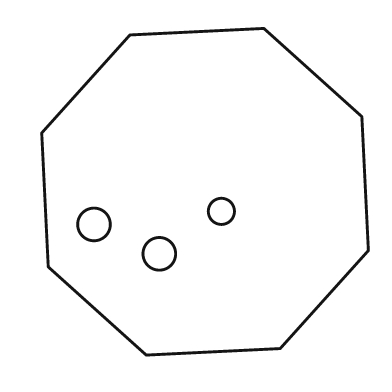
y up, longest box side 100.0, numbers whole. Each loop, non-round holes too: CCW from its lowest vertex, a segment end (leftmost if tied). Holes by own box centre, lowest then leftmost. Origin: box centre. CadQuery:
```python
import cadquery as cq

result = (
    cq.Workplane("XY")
    .moveTo(-18.0, -50.0)
    .lineTo(23.0, -48.0)
    .lineTo(50.0, -18.0)
    .lineTo(48.0, 23.0)
    .lineTo(18.0, 50.0)
    .lineTo(-23.0, 48.0)
    .lineTo(-50.0, 18.0)
    .lineTo(-48.0, -23.0)
    .close()
    .moveTo(-14.0, -19.0)
    .circle(5.0)
    .moveTo(-34.0, -10.0)
    .circle(5.0)
    .moveTo(5.0, -6.0)
    .circle(4.0)
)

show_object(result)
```